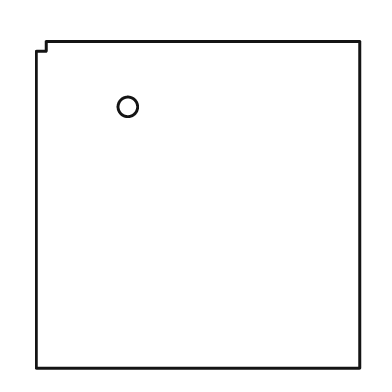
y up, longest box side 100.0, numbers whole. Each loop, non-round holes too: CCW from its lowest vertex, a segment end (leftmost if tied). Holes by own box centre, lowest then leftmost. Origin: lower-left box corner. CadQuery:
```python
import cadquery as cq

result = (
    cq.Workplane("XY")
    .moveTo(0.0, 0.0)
    .lineTo(99.0, 0.0)
    .lineTo(99.0, 100.0)
    .lineTo(3.0, 100.0)
    .lineTo(3.0, 97.0)
    .lineTo(0.0, 97.0)
    .close()
    .moveTo(28.0, 80.0)
    .circle(3.0)
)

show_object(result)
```